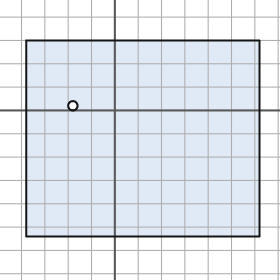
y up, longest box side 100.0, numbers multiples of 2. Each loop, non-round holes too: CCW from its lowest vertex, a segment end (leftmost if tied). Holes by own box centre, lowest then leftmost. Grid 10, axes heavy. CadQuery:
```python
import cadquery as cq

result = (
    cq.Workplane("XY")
    .moveTo(-38.0, -54.0)
    .lineTo(62.0, -54.0)
    .lineTo(62.0, 30.0)
    .lineTo(-38.0, 30.0)
    .close()
    .moveTo(-18.0, 2.0)
    .circle(2.0)
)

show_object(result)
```